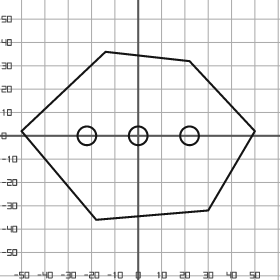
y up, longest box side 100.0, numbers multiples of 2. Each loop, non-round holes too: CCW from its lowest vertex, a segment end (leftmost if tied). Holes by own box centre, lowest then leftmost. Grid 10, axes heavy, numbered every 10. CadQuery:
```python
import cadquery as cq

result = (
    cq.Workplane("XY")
    .moveTo(-18.0, -36.0)
    .lineTo(30.0, -32.0)
    .lineTo(50.0, 2.0)
    .lineTo(22.0, 32.0)
    .lineTo(-14.0, 36.0)
    .lineTo(-50.0, 2.0)
    .close()
    .moveTo(-22.0, 0.0)
    .circle(4.0)
    .moveTo(0.0, 0.0)
    .circle(4.0)
    .moveTo(22.0, 0.0)
    .circle(4.0)
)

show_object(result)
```